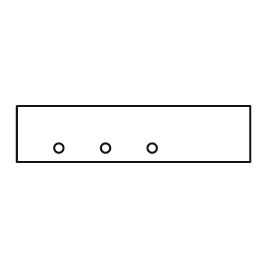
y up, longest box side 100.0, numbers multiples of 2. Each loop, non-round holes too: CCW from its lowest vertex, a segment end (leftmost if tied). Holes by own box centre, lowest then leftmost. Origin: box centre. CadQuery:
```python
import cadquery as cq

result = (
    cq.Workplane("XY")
    .moveTo(-50.0, -12.0)
    .lineTo(50.0, -12.0)
    .lineTo(50.0, 12.0)
    .lineTo(-50.0, 12.0)
    .close()
    .moveTo(-32.0, -6.0)
    .circle(2.0)
    .moveTo(-12.0, -6.0)
    .circle(2.0)
    .moveTo(8.0, -6.0)
    .circle(2.0)
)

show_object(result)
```